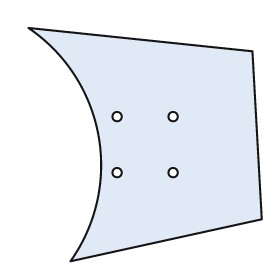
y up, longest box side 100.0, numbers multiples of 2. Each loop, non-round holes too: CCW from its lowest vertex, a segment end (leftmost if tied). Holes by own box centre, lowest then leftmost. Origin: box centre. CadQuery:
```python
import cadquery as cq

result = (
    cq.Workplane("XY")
    .moveTo(-32.0, -50.0)
    .lineTo(50.0, -32.0)
    .lineTo(46.0, 40.0)
    .lineTo(-50.0, 50.0)
    .threePointArc((-20.0, 4.0), (-32.0, -50.0))
    .close()
    .moveTo(-12.0, -12.0)
    .circle(2.0)
    .moveTo(12.0, -12.0)
    .circle(2.0)
    .moveTo(-12.0, 12.0)
    .circle(2.0)
    .moveTo(12.0, 12.0)
    .circle(2.0)
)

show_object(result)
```